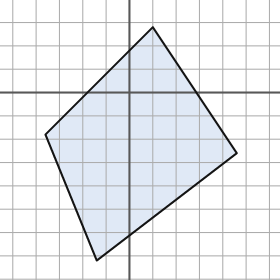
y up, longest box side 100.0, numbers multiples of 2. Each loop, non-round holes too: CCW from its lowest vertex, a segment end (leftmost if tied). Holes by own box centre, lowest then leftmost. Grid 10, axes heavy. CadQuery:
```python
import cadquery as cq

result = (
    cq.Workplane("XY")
    .moveTo(-14.0, -72.0)
    .lineTo(46.0, -26.0)
    .lineTo(10.0, 28.0)
    .lineTo(-36.0, -18.0)
    .close()
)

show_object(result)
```